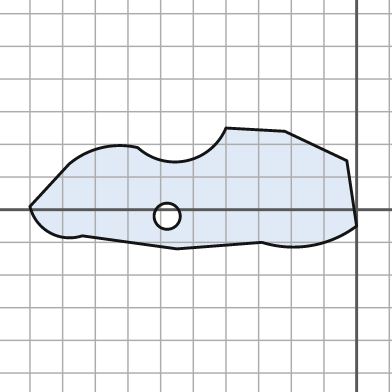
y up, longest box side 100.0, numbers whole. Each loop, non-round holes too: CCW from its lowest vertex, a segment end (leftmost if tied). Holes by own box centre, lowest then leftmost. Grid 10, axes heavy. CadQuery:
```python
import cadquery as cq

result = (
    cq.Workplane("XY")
    .moveTo(-55.0, -12.0)
    .lineTo(-29.0, -10.0)
    .threePointArc((-14.0, -11.0), (0.0, -5.0))
    .lineTo(-3.0, 15.0)
    .lineTo(-22.0, 24.0)
    .lineTo(-40.0, 25.0)
    .threePointArc((-52.0, 15.0), (-67.0, 19.0))
    .threePointArc((-78.0, 19.0), (-88.0, 14.0))
    .lineTo(-100.0, 1.0)
    .threePointArc((-94.0, -7.0), (-84.0, -8.0))
    .close()
    .moveTo(-58.0, -2.0)
    .circle(4.0)
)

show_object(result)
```